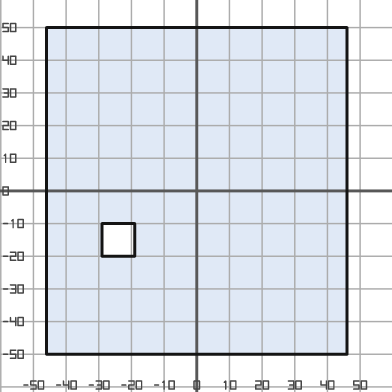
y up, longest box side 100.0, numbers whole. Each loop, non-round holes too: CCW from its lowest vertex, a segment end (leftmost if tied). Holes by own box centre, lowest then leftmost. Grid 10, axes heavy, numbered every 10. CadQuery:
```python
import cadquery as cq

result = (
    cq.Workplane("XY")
    .moveTo(-46.0, -50.0)
    .lineTo(46.0, -50.0)
    .lineTo(46.0, 50.0)
    .lineTo(-46.0, 50.0)
    .close()
    .moveTo(-29.0, -20.0)
    .lineTo(-19.0, -20.0)
    .lineTo(-19.0, -10.0)
    .lineTo(-29.0, -10.0)
    .close()
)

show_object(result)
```